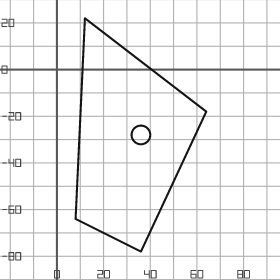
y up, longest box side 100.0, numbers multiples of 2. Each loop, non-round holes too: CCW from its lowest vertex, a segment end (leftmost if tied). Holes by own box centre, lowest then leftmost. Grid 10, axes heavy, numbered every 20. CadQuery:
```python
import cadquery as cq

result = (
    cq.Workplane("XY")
    .moveTo(36.0, -78.0)
    .lineTo(64.0, -18.0)
    .lineTo(12.0, 22.0)
    .lineTo(8.0, -64.0)
    .close()
    .moveTo(36.0, -28.0)
    .circle(4.0)
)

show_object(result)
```